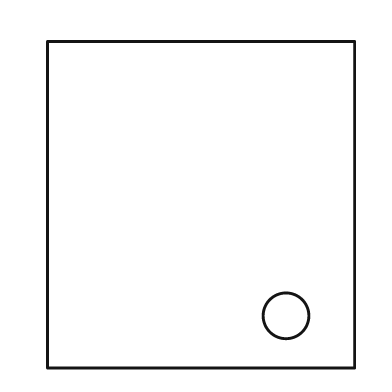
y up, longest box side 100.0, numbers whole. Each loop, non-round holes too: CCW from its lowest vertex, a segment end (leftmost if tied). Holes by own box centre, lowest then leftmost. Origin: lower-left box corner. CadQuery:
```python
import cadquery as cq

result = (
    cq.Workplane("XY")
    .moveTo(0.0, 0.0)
    .lineTo(94.0, 0.0)
    .lineTo(94.0, 100.0)
    .lineTo(0.0, 100.0)
    .close()
    .moveTo(73.0, 16.0)
    .circle(7.0)
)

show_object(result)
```